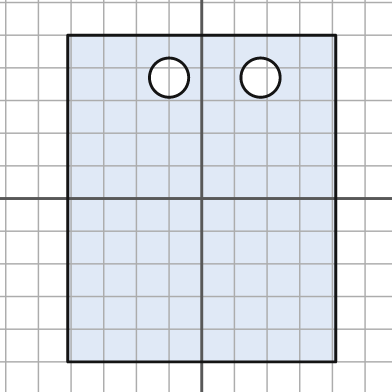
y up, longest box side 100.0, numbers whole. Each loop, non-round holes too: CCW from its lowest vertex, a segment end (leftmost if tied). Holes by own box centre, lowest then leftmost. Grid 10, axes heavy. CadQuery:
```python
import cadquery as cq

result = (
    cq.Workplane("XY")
    .moveTo(-41.0, -50.0)
    .lineTo(41.0, -50.0)
    .lineTo(41.0, 50.0)
    .lineTo(-41.0, 50.0)
    .close()
    .moveTo(-10.0, 37.0)
    .circle(6.0)
    .moveTo(18.0, 37.0)
    .circle(6.0)
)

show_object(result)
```